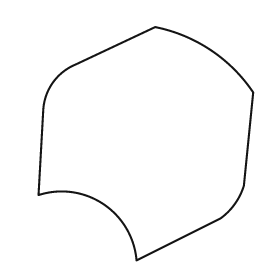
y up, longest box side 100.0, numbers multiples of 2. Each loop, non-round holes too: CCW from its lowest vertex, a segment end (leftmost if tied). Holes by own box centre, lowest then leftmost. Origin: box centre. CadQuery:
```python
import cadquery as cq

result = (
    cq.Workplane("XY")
    .moveTo(-4.0, -50.0)
    .lineTo(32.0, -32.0)
    .threePointArc((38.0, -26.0), (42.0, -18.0))
    .lineTo(46.0, 22.0)
    .threePointArc((28.0, 40.0), (4.0, 50.0))
    .lineTo(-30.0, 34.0)
    .threePointArc((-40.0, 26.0), (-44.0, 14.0))
    .lineTo(-46.0, -22.0)
    .threePointArc((-18.0, -26.0), (-4.0, -50.0))
    .close()
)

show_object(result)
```